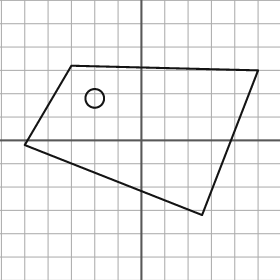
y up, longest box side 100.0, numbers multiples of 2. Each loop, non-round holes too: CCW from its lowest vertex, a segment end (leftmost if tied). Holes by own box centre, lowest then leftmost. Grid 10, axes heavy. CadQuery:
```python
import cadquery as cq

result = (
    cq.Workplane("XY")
    .moveTo(26.0, -32.0)
    .lineTo(50.0, 30.0)
    .lineTo(-30.0, 32.0)
    .lineTo(-50.0, -2.0)
    .close()
    .moveTo(-20.0, 18.0)
    .circle(4.0)
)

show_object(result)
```